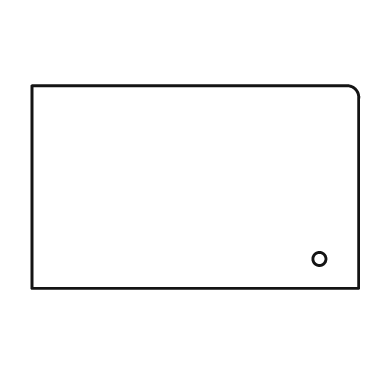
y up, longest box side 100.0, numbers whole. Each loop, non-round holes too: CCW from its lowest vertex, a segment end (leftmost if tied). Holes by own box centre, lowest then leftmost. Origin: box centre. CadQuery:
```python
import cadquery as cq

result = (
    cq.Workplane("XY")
    .moveTo(-50.0, -31.0)
    .lineTo(50.0, -31.0)
    .lineTo(50.0, 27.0)
    .threePointArc((49.0, 30.0), (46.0, 31.0))
    .lineTo(-50.0, 31.0)
    .close()
    .moveTo(38.0, -22.0)
    .circle(2.0)
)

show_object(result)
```